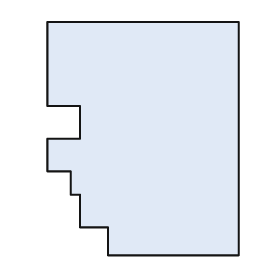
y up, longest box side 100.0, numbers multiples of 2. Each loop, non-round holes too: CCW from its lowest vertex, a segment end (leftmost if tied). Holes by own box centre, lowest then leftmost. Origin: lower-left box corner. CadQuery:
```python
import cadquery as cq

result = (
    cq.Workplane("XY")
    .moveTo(26.0, 0.0)
    .lineTo(82.0, 0.0)
    .lineTo(82.0, 100.0)
    .lineTo(0.0, 100.0)
    .lineTo(0.0, 64.0)
    .lineTo(14.0, 64.0)
    .lineTo(14.0, 50.0)
    .lineTo(0.0, 50.0)
    .lineTo(0.0, 36.0)
    .lineTo(10.0, 36.0)
    .lineTo(10.0, 26.0)
    .lineTo(14.0, 26.0)
    .lineTo(14.0, 12.0)
    .lineTo(26.0, 12.0)
    .close()
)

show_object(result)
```